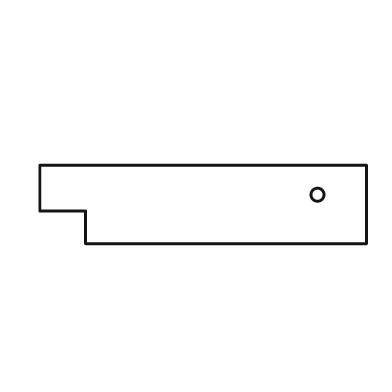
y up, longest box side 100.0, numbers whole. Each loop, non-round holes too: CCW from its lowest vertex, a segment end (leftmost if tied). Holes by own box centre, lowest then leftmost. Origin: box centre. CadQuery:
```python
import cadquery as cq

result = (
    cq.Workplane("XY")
    .moveTo(-36.0, -12.0)
    .lineTo(50.0, -12.0)
    .lineTo(50.0, 12.0)
    .lineTo(-50.0, 12.0)
    .lineTo(-50.0, -2.0)
    .lineTo(-36.0, -2.0)
    .close()
    .moveTo(35.0, 3.0)
    .circle(2.0)
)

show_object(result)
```